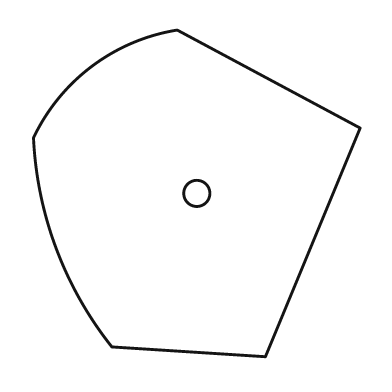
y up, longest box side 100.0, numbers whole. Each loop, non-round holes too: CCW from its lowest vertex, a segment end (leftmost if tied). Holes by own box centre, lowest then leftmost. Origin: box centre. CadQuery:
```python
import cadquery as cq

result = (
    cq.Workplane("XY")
    .moveTo(21.0, -50.0)
    .lineTo(50.0, 20.0)
    .lineTo(-6.0, 50.0)
    .threePointArc((-32.0, 39.0), (-50.0, 17.0))
    .threePointArc((-43.0, -17.0), (-26.0, -47.0))
    .close()
    .moveTo(0.0, 0.0)
    .circle(4.0)
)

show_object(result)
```